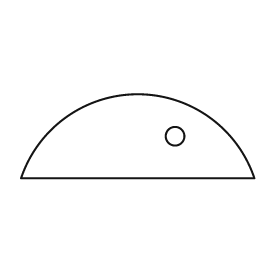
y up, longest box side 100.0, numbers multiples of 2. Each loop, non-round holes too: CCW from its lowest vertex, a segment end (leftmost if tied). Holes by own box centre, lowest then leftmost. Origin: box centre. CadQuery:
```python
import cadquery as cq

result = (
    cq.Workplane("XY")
    .moveTo(-50.0, -18.0)
    .lineTo(50.0, -18.0)
    .threePointArc((0.0, 18.0), (-50.0, -18.0))
    .close()
    .moveTo(16.0, 0.0)
    .circle(4.0)
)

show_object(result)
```